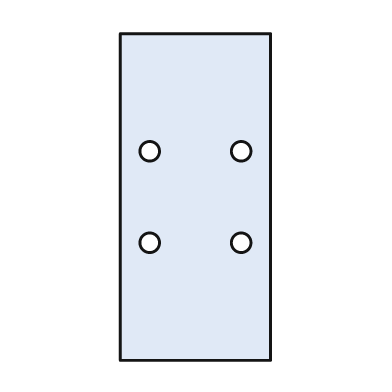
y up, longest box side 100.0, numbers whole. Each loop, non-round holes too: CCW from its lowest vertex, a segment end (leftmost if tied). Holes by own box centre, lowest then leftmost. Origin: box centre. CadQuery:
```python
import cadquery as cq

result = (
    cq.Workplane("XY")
    .moveTo(-23.0, -50.0)
    .lineTo(23.0, -50.0)
    .lineTo(23.0, 50.0)
    .lineTo(-23.0, 50.0)
    .close()
    .moveTo(-14.0, -14.0)
    .circle(3.0)
    .moveTo(14.0, -14.0)
    .circle(3.0)
    .moveTo(-14.0, 14.0)
    .circle(3.0)
    .moveTo(14.0, 14.0)
    .circle(3.0)
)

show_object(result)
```